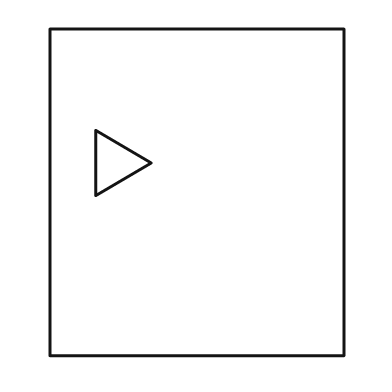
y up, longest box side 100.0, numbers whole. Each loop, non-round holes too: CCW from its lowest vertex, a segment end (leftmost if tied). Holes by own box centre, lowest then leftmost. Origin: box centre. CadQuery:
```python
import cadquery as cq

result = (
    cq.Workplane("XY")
    .moveTo(-45.0, -50.0)
    .lineTo(45.0, -50.0)
    .lineTo(45.0, 50.0)
    .lineTo(-45.0, 50.0)
    .close()
    .moveTo(-31.0, -1.0)
    .lineTo(-14.0, 9.0)
    .lineTo(-31.0, 19.0)
    .close()
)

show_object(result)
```